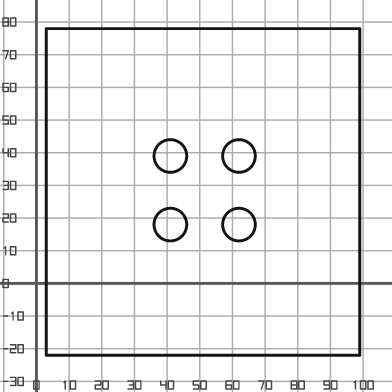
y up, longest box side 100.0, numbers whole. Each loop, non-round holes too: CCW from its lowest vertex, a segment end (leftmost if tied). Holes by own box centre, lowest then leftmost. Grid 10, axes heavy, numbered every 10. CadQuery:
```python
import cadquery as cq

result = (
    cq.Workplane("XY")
    .moveTo(3.0, -22.0)
    .lineTo(99.0, -22.0)
    .lineTo(99.0, 78.0)
    .lineTo(3.0, 78.0)
    .close()
    .moveTo(41.0, 18.0)
    .circle(5.0)
    .moveTo(62.0, 18.0)
    .circle(5.0)
    .moveTo(41.0, 39.0)
    .circle(5.0)
    .moveTo(62.0, 39.0)
    .circle(5.0)
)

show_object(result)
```